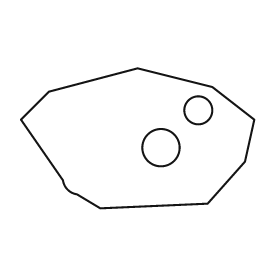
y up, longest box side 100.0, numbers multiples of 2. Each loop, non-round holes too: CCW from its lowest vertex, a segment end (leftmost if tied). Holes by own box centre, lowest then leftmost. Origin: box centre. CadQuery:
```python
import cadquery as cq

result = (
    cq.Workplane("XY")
    .moveTo(-16.0, -30.0)
    .lineTo(30.0, -28.0)
    .lineTo(46.0, -10.0)
    .lineTo(50.0, 8.0)
    .lineTo(32.0, 22.0)
    .lineTo(0.0, 30.0)
    .lineTo(-38.0, 20.0)
    .lineTo(-50.0, 8.0)
    .lineTo(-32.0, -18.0)
    .threePointArc((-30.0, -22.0), (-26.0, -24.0))
    .close()
    .moveTo(10.0, -4.0)
    .circle(8.0)
    .moveTo(26.0, 12.0)
    .circle(6.0)
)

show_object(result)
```